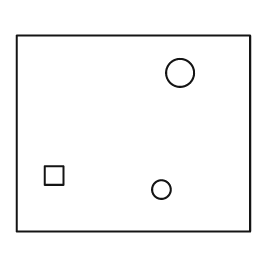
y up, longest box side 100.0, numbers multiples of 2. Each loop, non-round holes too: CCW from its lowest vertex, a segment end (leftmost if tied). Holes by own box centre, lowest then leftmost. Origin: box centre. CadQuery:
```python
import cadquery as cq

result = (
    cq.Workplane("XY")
    .moveTo(-50.0, -42.0)
    .lineTo(50.0, -42.0)
    .lineTo(50.0, 42.0)
    .lineTo(-50.0, 42.0)
    .close()
    .moveTo(12.0, -24.0)
    .circle(4.0)
    .moveTo(-38.0, -22.0)
    .lineTo(-30.0, -22.0)
    .lineTo(-30.0, -14.0)
    .lineTo(-38.0, -14.0)
    .close()
    .moveTo(20.0, 26.0)
    .circle(6.0)
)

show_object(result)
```